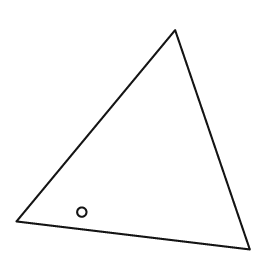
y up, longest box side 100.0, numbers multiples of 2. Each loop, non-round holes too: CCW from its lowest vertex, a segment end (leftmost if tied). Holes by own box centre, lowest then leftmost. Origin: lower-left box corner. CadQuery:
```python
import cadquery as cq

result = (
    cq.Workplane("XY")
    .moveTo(100.0, 0.0)
    .lineTo(68.0, 94.0)
    .lineTo(0.0, 12.0)
    .close()
    .moveTo(28.0, 16.0)
    .circle(2.0)
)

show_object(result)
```